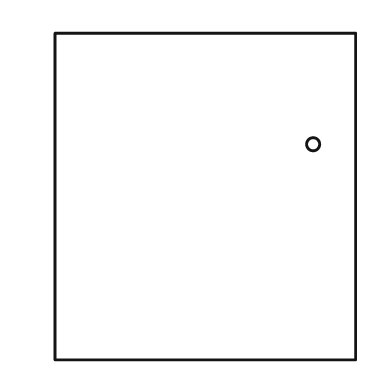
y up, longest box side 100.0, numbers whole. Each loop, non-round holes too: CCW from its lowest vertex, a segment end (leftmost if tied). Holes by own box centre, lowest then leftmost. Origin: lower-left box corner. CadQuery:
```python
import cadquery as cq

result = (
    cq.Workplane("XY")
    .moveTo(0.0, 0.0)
    .lineTo(92.0, 0.0)
    .lineTo(92.0, 100.0)
    .lineTo(0.0, 100.0)
    .close()
    .moveTo(79.0, 66.0)
    .circle(2.0)
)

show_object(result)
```